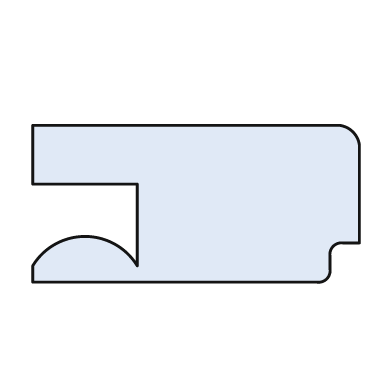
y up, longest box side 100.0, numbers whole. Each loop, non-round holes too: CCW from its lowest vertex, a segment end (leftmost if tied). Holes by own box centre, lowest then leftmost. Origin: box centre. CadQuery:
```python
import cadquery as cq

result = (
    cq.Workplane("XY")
    .moveTo(-50.0, -24.0)
    .lineTo(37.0, -24.0)
    .threePointArc((40.0, -23.0), (41.0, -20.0))
    .lineTo(41.0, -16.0)
    .threePointArc((42.0, -13.0), (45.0, -12.0))
    .lineTo(50.0, -12.0)
    .lineTo(50.0, 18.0)
    .threePointArc((48.0, 22.0), (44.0, 24.0))
    .lineTo(-50.0, 24.0)
    .lineTo(-50.0, 6.0)
    .lineTo(-18.0, 6.0)
    .lineTo(-18.0, -19.0)
    .threePointArc((-34.0, -10.0), (-50.0, -19.0))
    .close()
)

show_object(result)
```